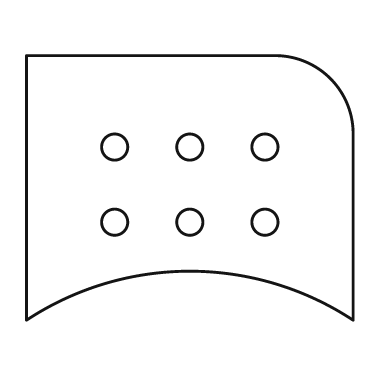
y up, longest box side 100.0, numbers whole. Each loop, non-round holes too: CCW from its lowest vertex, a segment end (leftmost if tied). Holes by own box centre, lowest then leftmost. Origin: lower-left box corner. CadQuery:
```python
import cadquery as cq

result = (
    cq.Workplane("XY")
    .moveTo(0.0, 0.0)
    .threePointArc((50.0, 15.0), (100.0, 0.0))
    .lineTo(100.0, 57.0)
    .threePointArc((93.0, 74.0), (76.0, 81.0))
    .lineTo(0.0, 81.0)
    .close()
    .moveTo(27.0, 30.0)
    .circle(4.0)
    .moveTo(50.0, 30.0)
    .circle(4.0)
    .moveTo(73.0, 30.0)
    .circle(4.0)
    .moveTo(27.0, 53.0)
    .circle(4.0)
    .moveTo(50.0, 53.0)
    .circle(4.0)
    .moveTo(73.0, 53.0)
    .circle(4.0)
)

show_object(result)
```